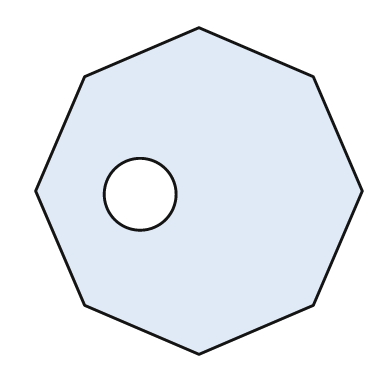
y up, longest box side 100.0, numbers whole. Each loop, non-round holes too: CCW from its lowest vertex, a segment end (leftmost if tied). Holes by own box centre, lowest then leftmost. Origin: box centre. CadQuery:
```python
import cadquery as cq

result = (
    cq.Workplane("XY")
    .moveTo(0.0, -50.0)
    .lineTo(35.0, -35.0)
    .lineTo(50.0, 0.0)
    .lineTo(35.0, 35.0)
    .lineTo(0.0, 50.0)
    .lineTo(-35.0, 35.0)
    .lineTo(-50.0, 0.0)
    .lineTo(-35.0, -35.0)
    .close()
    .moveTo(-18.0, -1.0)
    .circle(11.0)
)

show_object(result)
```